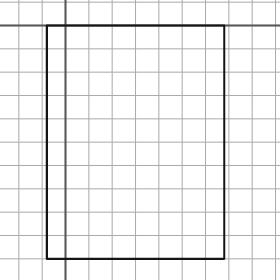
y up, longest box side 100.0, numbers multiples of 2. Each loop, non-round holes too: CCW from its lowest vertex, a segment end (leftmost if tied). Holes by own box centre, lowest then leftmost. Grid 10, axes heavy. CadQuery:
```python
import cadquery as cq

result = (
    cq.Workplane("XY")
    .moveTo(-8.0, -100.0)
    .lineTo(68.0, -100.0)
    .lineTo(68.0, 0.0)
    .lineTo(-8.0, 0.0)
    .close()
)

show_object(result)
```